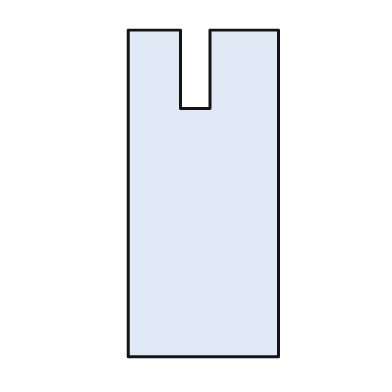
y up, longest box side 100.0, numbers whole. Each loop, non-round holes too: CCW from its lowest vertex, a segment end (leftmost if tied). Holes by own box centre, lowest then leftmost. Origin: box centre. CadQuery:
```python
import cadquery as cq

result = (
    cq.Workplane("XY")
    .moveTo(-23.0, -50.0)
    .lineTo(23.0, -50.0)
    .lineTo(23.0, 50.0)
    .lineTo(2.0, 50.0)
    .lineTo(2.0, 26.0)
    .lineTo(-7.0, 26.0)
    .lineTo(-7.0, 50.0)
    .lineTo(-23.0, 50.0)
    .close()
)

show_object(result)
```